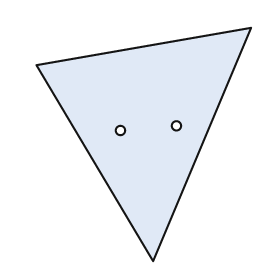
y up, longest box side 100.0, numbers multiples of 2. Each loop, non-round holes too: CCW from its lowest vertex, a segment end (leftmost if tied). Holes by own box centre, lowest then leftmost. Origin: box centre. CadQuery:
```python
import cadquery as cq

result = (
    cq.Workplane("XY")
    .moveTo(4.0, -50.0)
    .lineTo(46.0, 50.0)
    .lineTo(-46.0, 34.0)
    .close()
    .moveTo(-10.0, 6.0)
    .circle(2.0)
    .moveTo(14.0, 8.0)
    .circle(2.0)
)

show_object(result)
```